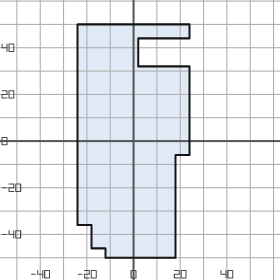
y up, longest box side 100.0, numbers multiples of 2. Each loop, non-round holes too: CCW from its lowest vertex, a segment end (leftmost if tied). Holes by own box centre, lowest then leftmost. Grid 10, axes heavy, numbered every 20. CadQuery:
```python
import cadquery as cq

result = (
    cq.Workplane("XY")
    .moveTo(-12.0, -50.0)
    .lineTo(18.0, -50.0)
    .lineTo(18.0, -6.0)
    .lineTo(24.0, -6.0)
    .lineTo(24.0, 32.0)
    .lineTo(2.0, 32.0)
    .lineTo(2.0, 44.0)
    .lineTo(24.0, 44.0)
    .lineTo(24.0, 50.0)
    .lineTo(-24.0, 50.0)
    .lineTo(-24.0, -36.0)
    .lineTo(-18.0, -36.0)
    .lineTo(-18.0, -46.0)
    .lineTo(-12.0, -46.0)
    .close()
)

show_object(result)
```